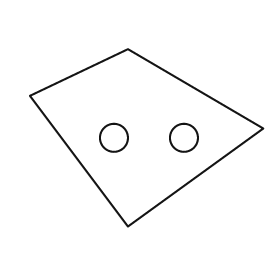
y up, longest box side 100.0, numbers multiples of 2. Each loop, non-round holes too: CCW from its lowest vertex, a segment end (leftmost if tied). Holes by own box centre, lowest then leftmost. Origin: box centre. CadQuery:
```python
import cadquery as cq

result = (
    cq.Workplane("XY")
    .moveTo(-8.0, -38.0)
    .lineTo(50.0, 4.0)
    .lineTo(-8.0, 38.0)
    .lineTo(-50.0, 18.0)
    .close()
    .moveTo(-14.0, 0.0)
    .circle(6.0)
    .moveTo(16.0, 0.0)
    .circle(6.0)
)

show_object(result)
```